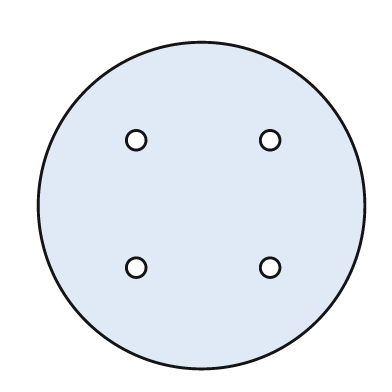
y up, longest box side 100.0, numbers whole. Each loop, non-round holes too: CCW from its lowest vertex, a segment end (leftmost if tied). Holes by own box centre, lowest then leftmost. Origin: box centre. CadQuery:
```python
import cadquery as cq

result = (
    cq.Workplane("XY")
    .moveTo(0.0, 0.0)
    .circle(50.0)
    .moveTo(-20.0, -19.0)
    .circle(3.0)
    .moveTo(21.0, -19.0)
    .circle(3.0)
    .moveTo(-20.0, 20.0)
    .circle(3.0)
    .moveTo(21.0, 20.0)
    .circle(3.0)
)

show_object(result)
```